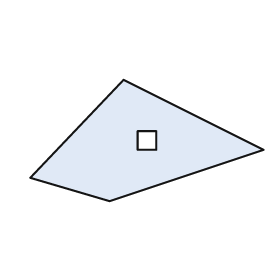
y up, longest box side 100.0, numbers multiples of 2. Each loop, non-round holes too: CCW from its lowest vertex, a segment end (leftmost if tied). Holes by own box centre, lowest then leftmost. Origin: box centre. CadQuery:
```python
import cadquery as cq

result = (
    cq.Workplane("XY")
    .moveTo(-16.0, -26.0)
    .lineTo(50.0, -4.0)
    .lineTo(-10.0, 26.0)
    .lineTo(-50.0, -16.0)
    .close()
    .moveTo(-4.0, -4.0)
    .lineTo(4.0, -4.0)
    .lineTo(4.0, 4.0)
    .lineTo(-4.0, 4.0)
    .close()
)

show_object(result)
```